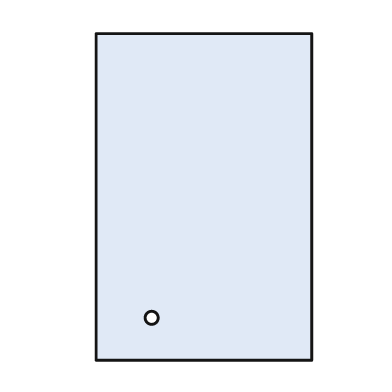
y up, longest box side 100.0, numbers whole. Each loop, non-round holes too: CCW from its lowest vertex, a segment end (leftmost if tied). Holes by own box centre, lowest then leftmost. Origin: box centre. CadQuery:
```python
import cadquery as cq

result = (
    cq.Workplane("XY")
    .moveTo(-33.0, -50.0)
    .lineTo(33.0, -50.0)
    .lineTo(33.0, 50.0)
    .lineTo(-33.0, 50.0)
    .close()
    .moveTo(-16.0, -37.0)
    .circle(2.0)
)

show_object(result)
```